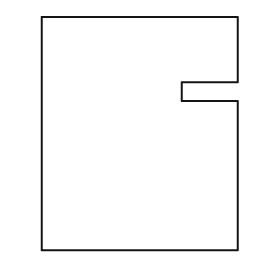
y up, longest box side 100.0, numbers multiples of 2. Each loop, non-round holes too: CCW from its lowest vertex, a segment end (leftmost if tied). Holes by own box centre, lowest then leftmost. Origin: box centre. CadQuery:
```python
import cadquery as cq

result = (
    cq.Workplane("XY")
    .moveTo(-42.0, -50.0)
    .lineTo(42.0, -50.0)
    .lineTo(42.0, 14.0)
    .lineTo(18.0, 14.0)
    .lineTo(18.0, 22.0)
    .lineTo(42.0, 22.0)
    .lineTo(42.0, 50.0)
    .lineTo(-42.0, 50.0)
    .close()
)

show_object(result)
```